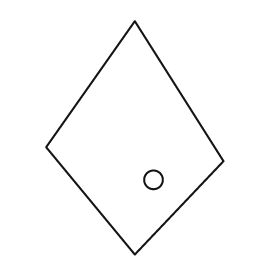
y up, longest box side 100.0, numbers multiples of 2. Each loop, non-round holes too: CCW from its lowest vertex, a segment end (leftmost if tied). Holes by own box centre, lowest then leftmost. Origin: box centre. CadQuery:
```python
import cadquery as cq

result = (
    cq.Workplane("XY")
    .moveTo(0.0, -50.0)
    .lineTo(38.0, -10.0)
    .lineTo(0.0, 50.0)
    .lineTo(-38.0, -4.0)
    .close()
    .moveTo(8.0, -18.0)
    .circle(4.0)
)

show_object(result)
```